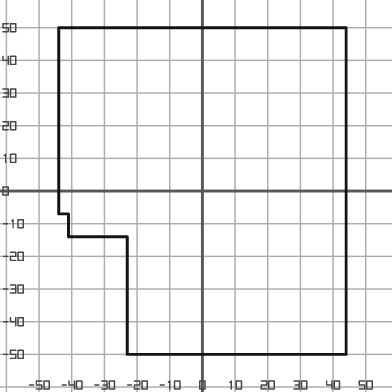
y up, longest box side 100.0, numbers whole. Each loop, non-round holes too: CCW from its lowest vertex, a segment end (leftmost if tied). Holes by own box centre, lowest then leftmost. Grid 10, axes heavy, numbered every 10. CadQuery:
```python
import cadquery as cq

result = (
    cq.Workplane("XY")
    .moveTo(-23.0, -50.0)
    .lineTo(44.0, -50.0)
    .lineTo(44.0, 50.0)
    .lineTo(-44.0, 50.0)
    .lineTo(-44.0, -7.0)
    .lineTo(-41.0, -7.0)
    .lineTo(-41.0, -14.0)
    .lineTo(-23.0, -14.0)
    .close()
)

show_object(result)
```